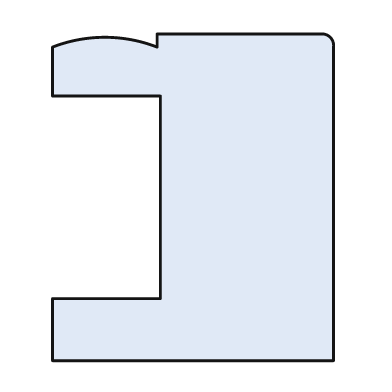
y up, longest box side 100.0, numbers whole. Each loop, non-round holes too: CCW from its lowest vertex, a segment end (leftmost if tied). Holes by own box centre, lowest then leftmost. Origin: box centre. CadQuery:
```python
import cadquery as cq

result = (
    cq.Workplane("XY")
    .moveTo(-43.0, -50.0)
    .lineTo(43.0, -50.0)
    .lineTo(43.0, 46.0)
    .threePointArc((42.0, 49.0), (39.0, 50.0))
    .lineTo(-11.0, 50.0)
    .lineTo(-11.0, 46.0)
    .threePointArc((-27.0, 49.0), (-43.0, 46.0))
    .lineTo(-43.0, 31.0)
    .lineTo(-10.0, 31.0)
    .lineTo(-10.0, -31.0)
    .lineTo(-43.0, -31.0)
    .close()
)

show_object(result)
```